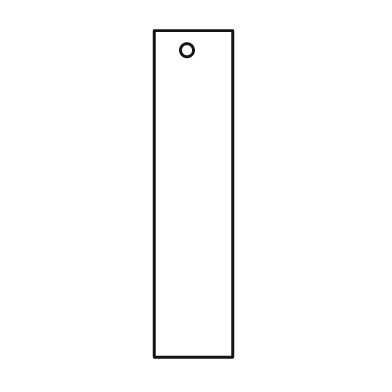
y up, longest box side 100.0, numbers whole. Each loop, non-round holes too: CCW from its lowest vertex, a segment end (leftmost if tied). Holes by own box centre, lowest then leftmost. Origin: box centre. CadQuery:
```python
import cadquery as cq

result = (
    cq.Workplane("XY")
    .moveTo(-12.0, -50.0)
    .lineTo(12.0, -50.0)
    .lineTo(12.0, 50.0)
    .lineTo(-12.0, 50.0)
    .close()
    .moveTo(-2.0, 44.0)
    .circle(2.0)
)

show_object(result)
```